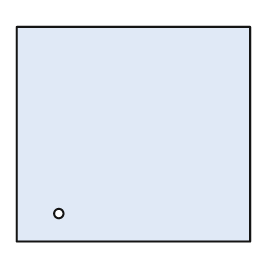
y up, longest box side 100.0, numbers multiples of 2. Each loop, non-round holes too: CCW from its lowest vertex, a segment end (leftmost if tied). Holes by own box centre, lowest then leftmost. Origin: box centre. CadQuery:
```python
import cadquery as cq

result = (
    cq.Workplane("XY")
    .moveTo(-50.0, -46.0)
    .lineTo(50.0, -46.0)
    .lineTo(50.0, 46.0)
    .lineTo(-50.0, 46.0)
    .close()
    .moveTo(-32.0, -34.0)
    .circle(2.0)
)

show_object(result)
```